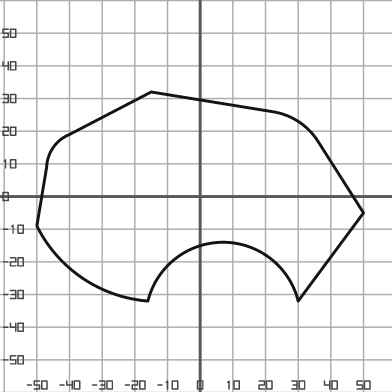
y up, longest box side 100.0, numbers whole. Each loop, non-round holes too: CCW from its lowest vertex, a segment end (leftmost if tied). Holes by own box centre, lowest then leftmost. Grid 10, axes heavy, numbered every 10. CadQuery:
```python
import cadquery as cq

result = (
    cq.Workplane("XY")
    .moveTo(-16.0, -32.0)
    .threePointArc((7.0, -14.0), (30.0, -32.0))
    .lineTo(50.0, -5.0)
    .lineTo(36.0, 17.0)
    .threePointArc((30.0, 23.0), (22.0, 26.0))
    .lineTo(-15.0, 32.0)
    .lineTo(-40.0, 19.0)
    .threePointArc((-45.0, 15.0), (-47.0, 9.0))
    .lineTo(-50.0, -9.0)
    .threePointArc((-36.0, -25.0), (-16.0, -32.0))
    .close()
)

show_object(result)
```